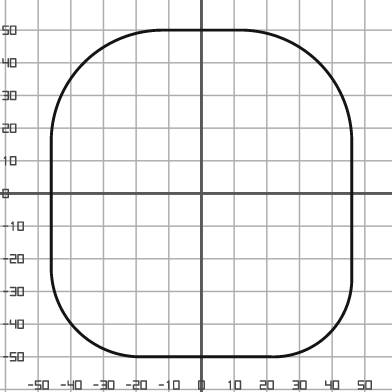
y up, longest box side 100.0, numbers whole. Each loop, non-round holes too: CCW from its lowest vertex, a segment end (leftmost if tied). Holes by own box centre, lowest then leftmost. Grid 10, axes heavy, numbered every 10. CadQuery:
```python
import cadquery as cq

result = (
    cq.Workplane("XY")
    .moveTo(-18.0, -50.0)
    .lineTo(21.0, -50.0)
    .threePointArc((39.0, -43.0), (46.0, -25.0))
    .lineTo(46.0, 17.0)
    .threePointArc((36.0, 40.0), (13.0, 50.0))
    .lineTo(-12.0, 50.0)
    .threePointArc((-36.0, 40.0), (-46.0, 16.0))
    .lineTo(-46.0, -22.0)
    .threePointArc((-38.0, -42.0), (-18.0, -50.0))
    .close()
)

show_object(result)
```